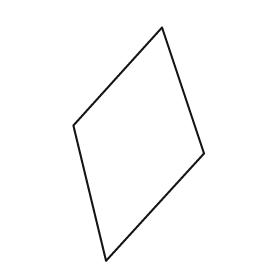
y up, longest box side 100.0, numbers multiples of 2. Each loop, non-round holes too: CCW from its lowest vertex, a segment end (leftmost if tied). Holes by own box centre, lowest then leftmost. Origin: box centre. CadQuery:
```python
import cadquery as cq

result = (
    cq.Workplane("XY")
    .moveTo(-14.0, -50.0)
    .lineTo(28.0, -4.0)
    .lineTo(10.0, 50.0)
    .lineTo(-28.0, 8.0)
    .close()
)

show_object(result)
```